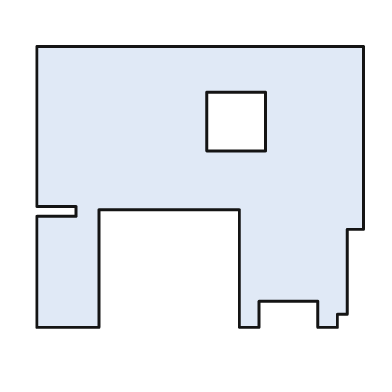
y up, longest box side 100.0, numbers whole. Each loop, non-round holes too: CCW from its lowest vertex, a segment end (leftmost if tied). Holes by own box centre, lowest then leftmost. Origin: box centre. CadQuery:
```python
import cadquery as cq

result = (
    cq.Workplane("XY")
    .moveTo(-50.0, -43.0)
    .lineTo(-31.0, -43.0)
    .lineTo(-31.0, -7.0)
    .lineTo(12.0, -7.0)
    .lineTo(12.0, -43.0)
    .lineTo(18.0, -43.0)
    .lineTo(18.0, -35.0)
    .lineTo(36.0, -35.0)
    .lineTo(36.0, -43.0)
    .lineTo(42.0, -43.0)
    .lineTo(42.0, -39.0)
    .lineTo(45.0, -39.0)
    .lineTo(45.0, -13.0)
    .lineTo(50.0, -13.0)
    .lineTo(50.0, 43.0)
    .lineTo(-50.0, 43.0)
    .lineTo(-50.0, -6.0)
    .lineTo(-38.0, -6.0)
    .lineTo(-38.0, -9.0)
    .lineTo(-50.0, -9.0)
    .close()
    .moveTo(2.0, 11.0)
    .lineTo(20.0, 11.0)
    .lineTo(20.0, 29.0)
    .lineTo(2.0, 29.0)
    .close()
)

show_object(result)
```